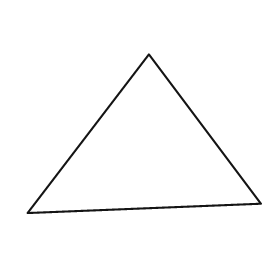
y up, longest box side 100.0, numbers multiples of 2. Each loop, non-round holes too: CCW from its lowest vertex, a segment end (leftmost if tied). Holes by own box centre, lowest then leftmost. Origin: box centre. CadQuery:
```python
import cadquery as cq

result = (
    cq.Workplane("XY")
    .moveTo(-50.0, -34.0)
    .lineTo(50.0, -30.0)
    .lineTo(2.0, 34.0)
    .close()
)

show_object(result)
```